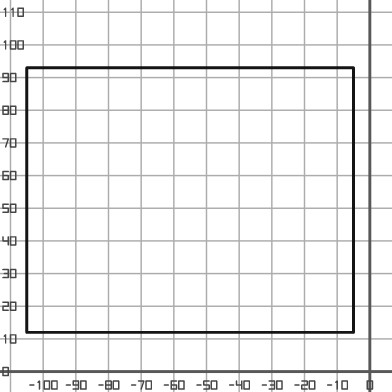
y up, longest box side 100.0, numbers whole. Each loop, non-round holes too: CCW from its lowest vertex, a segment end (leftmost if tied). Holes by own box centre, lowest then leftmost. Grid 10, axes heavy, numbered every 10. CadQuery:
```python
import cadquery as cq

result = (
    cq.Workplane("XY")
    .moveTo(-105.0, 12.0)
    .lineTo(-5.0, 12.0)
    .lineTo(-5.0, 93.0)
    .lineTo(-105.0, 93.0)
    .close()
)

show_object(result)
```